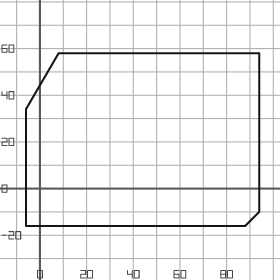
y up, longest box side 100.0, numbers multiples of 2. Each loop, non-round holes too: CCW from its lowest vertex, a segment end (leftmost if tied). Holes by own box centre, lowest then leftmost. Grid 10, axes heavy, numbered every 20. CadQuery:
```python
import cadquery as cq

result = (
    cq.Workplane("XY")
    .moveTo(-6.0, -16.0)
    .lineTo(88.0, -16.0)
    .lineTo(94.0, -10.0)
    .lineTo(94.0, 58.0)
    .lineTo(8.0, 58.0)
    .lineTo(-6.0, 34.0)
    .close()
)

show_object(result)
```